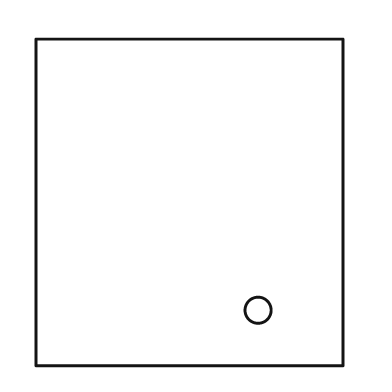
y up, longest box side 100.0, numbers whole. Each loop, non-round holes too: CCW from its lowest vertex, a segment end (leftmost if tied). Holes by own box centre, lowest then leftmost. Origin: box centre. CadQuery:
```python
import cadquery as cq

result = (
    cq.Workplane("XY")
    .moveTo(-47.0, -50.0)
    .lineTo(47.0, -50.0)
    .lineTo(47.0, 50.0)
    .lineTo(-47.0, 50.0)
    .close()
    .moveTo(21.0, -33.0)
    .circle(4.0)
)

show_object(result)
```